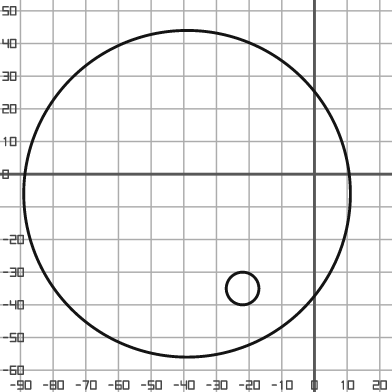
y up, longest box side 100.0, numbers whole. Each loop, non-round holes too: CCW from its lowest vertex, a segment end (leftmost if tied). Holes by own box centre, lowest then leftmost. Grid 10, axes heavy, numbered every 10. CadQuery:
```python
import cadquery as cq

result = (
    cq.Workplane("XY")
    .moveTo(-39.0, -6.0)
    .circle(50.0)
    .moveTo(-22.0, -35.0)
    .circle(5.0)
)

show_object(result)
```